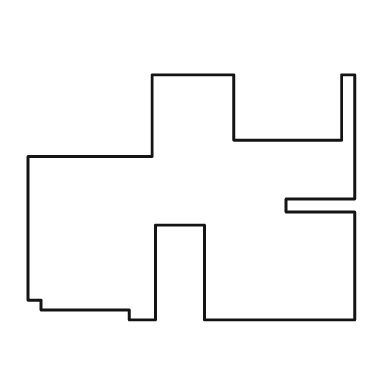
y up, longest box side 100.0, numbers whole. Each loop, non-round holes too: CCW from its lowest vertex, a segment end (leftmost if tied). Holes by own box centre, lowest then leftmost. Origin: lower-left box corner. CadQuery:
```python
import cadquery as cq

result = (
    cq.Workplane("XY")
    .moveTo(31.0, 0.0)
    .lineTo(39.0, 0.0)
    .lineTo(39.0, 29.0)
    .lineTo(54.0, 29.0)
    .lineTo(54.0, 0.0)
    .lineTo(100.0, 0.0)
    .lineTo(100.0, 33.0)
    .lineTo(79.0, 33.0)
    .lineTo(79.0, 37.0)
    .lineTo(100.0, 37.0)
    .lineTo(100.0, 75.0)
    .lineTo(96.0, 75.0)
    .lineTo(96.0, 55.0)
    .lineTo(63.0, 55.0)
    .lineTo(63.0, 75.0)
    .lineTo(38.0, 75.0)
    .lineTo(38.0, 50.0)
    .lineTo(0.0, 50.0)
    .lineTo(0.0, 6.0)
    .lineTo(4.0, 6.0)
    .lineTo(4.0, 3.0)
    .lineTo(31.0, 3.0)
    .close()
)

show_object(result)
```